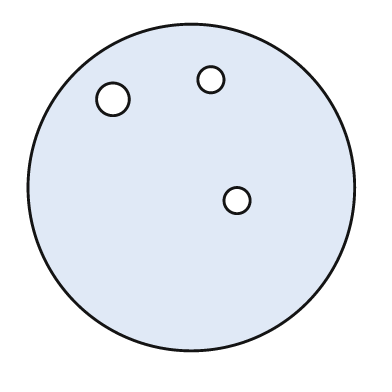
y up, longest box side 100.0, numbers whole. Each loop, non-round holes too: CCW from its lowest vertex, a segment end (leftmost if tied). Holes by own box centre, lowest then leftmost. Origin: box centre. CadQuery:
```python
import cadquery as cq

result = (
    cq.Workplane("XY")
    .moveTo(0.0, 0.0)
    .circle(50.0)
    .moveTo(14.0, -4.0)
    .circle(4.0)
    .moveTo(-24.0, 27.0)
    .circle(5.0)
    .moveTo(6.0, 33.0)
    .circle(4.0)
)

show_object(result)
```